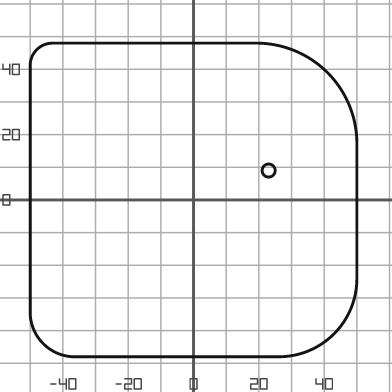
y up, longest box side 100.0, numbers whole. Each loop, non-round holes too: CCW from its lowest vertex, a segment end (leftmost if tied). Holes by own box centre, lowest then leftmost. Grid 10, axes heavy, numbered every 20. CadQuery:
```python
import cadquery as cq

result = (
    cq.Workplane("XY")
    .moveTo(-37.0, -48.0)
    .lineTo(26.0, -48.0)
    .threePointArc((43.0, -41.0), (50.0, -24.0))
    .lineTo(50.0, 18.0)
    .threePointArc((41.0, 39.0), (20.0, 48.0))
    .lineTo(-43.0, 48.0)
    .threePointArc((-48.0, 46.0), (-50.0, 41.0))
    .lineTo(-50.0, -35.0)
    .threePointArc((-46.0, -44.0), (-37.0, -48.0))
    .close()
    .moveTo(23.0, 9.0)
    .circle(2.0)
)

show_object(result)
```